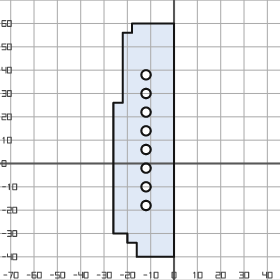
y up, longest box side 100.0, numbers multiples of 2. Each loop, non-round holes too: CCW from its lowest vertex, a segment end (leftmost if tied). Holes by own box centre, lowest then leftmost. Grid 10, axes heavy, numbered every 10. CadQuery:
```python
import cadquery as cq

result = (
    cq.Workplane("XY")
    .moveTo(-16.0, -40.0)
    .lineTo(0.0, -40.0)
    .lineTo(0.0, 60.0)
    .lineTo(-18.0, 60.0)
    .lineTo(-18.0, 56.0)
    .lineTo(-22.0, 56.0)
    .lineTo(-22.0, 26.0)
    .lineTo(-26.0, 26.0)
    .lineTo(-26.0, -30.0)
    .lineTo(-20.0, -30.0)
    .lineTo(-20.0, -34.0)
    .lineTo(-16.0, -34.0)
    .close()
    .moveTo(-12.0, -18.0)
    .circle(2.0)
    .moveTo(-12.0, -10.0)
    .circle(2.0)
    .moveTo(-12.0, -2.0)
    .circle(2.0)
    .moveTo(-12.0, 6.0)
    .circle(2.0)
    .moveTo(-12.0, 14.0)
    .circle(2.0)
    .moveTo(-12.0, 22.0)
    .circle(2.0)
    .moveTo(-12.0, 30.0)
    .circle(2.0)
    .moveTo(-12.0, 38.0)
    .circle(2.0)
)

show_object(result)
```